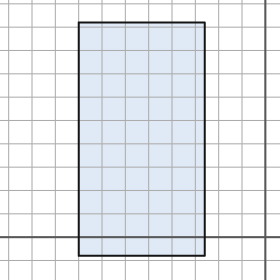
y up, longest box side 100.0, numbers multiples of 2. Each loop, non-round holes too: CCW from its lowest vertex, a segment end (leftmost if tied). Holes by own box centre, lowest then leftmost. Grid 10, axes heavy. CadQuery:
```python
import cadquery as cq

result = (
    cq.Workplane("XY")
    .moveTo(-80.0, -8.0)
    .lineTo(-26.0, -8.0)
    .lineTo(-26.0, 92.0)
    .lineTo(-80.0, 92.0)
    .close()
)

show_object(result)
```